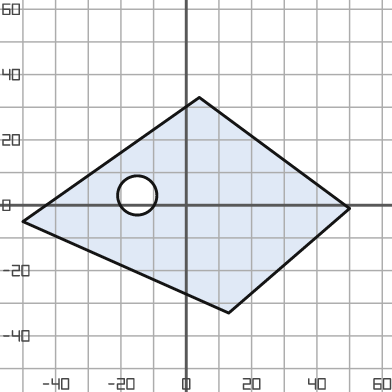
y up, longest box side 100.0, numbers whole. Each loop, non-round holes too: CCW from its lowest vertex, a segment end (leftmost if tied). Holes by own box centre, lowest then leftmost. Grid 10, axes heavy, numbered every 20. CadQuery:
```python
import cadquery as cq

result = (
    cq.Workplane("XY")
    .moveTo(13.0, -33.0)
    .lineTo(50.0, -1.0)
    .lineTo(4.0, 33.0)
    .lineTo(-50.0, -5.0)
    .close()
    .moveTo(-15.0, 3.0)
    .circle(6.0)
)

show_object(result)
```